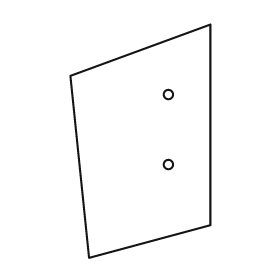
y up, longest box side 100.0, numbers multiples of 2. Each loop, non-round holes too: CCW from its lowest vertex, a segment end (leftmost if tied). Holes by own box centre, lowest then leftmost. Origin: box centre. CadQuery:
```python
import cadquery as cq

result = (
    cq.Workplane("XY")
    .moveTo(-22.0, -50.0)
    .lineTo(30.0, -36.0)
    .lineTo(30.0, 50.0)
    .lineTo(-30.0, 28.0)
    .close()
    .moveTo(12.0, -10.0)
    .circle(2.0)
    .moveTo(12.0, 20.0)
    .circle(2.0)
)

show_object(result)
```